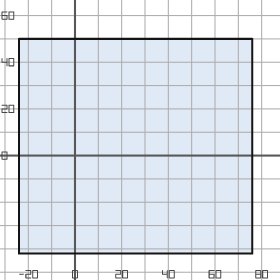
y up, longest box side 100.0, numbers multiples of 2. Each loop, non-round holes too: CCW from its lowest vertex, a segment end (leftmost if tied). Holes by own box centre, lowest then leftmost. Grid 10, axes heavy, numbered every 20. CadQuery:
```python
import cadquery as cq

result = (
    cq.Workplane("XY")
    .moveTo(-24.0, -42.0)
    .lineTo(76.0, -42.0)
    .lineTo(76.0, 50.0)
    .lineTo(-24.0, 50.0)
    .close()
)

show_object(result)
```